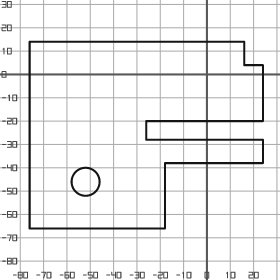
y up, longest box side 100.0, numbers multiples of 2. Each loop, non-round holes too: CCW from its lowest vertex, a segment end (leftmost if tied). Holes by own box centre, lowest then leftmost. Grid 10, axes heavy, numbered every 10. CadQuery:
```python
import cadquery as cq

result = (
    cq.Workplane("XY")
    .moveTo(-76.0, -66.0)
    .lineTo(-18.0, -66.0)
    .lineTo(-18.0, -38.0)
    .lineTo(24.0, -38.0)
    .lineTo(24.0, -28.0)
    .lineTo(-26.0, -28.0)
    .lineTo(-26.0, -20.0)
    .lineTo(24.0, -20.0)
    .lineTo(24.0, 4.0)
    .lineTo(16.0, 4.0)
    .lineTo(16.0, 14.0)
    .lineTo(-76.0, 14.0)
    .close()
    .moveTo(-52.0, -46.0)
    .circle(6.0)
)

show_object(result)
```